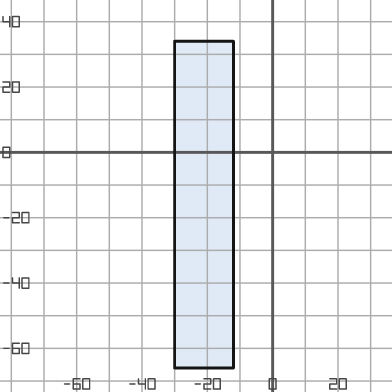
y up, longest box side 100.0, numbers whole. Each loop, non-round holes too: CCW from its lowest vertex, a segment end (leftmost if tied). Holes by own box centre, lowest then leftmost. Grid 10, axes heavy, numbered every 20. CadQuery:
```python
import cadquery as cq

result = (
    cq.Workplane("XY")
    .moveTo(-30.0, -66.0)
    .lineTo(-12.0, -66.0)
    .lineTo(-12.0, 34.0)
    .lineTo(-30.0, 34.0)
    .close()
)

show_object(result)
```